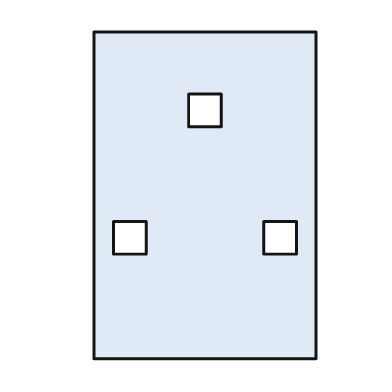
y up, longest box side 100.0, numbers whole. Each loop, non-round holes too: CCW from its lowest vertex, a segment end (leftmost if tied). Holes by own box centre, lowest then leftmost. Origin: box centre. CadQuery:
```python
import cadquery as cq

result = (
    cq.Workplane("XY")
    .moveTo(-34.0, -50.0)
    .lineTo(34.0, -50.0)
    .lineTo(34.0, 50.0)
    .lineTo(-34.0, 50.0)
    .close()
    .moveTo(-28.0, -18.0)
    .lineTo(-18.0, -18.0)
    .lineTo(-18.0, -8.0)
    .lineTo(-28.0, -8.0)
    .close()
    .moveTo(18.0, -18.0)
    .lineTo(28.0, -18.0)
    .lineTo(28.0, -8.0)
    .lineTo(18.0, -8.0)
    .close()
    .moveTo(-5.0, 21.0)
    .lineTo(5.0, 21.0)
    .lineTo(5.0, 31.0)
    .lineTo(-5.0, 31.0)
    .close()
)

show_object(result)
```